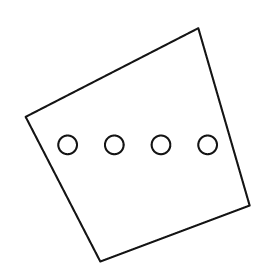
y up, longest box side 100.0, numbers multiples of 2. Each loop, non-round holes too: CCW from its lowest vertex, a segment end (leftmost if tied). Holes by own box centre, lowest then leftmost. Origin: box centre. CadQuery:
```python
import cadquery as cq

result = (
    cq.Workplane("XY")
    .moveTo(-16.0, -50.0)
    .lineTo(48.0, -26.0)
    .lineTo(26.0, 50.0)
    .lineTo(-48.0, 12.0)
    .close()
    .moveTo(-30.0, 0.0)
    .circle(4.0)
    .moveTo(-10.0, 0.0)
    .circle(4.0)
    .moveTo(10.0, 0.0)
    .circle(4.0)
    .moveTo(30.0, 0.0)
    .circle(4.0)
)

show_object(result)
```